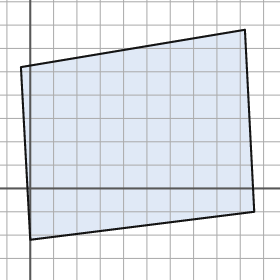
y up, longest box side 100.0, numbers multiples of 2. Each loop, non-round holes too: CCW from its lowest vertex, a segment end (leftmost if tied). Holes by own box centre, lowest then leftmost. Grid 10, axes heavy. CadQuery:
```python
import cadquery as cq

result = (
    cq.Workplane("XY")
    .moveTo(0.0, -22.0)
    .lineTo(96.0, -10.0)
    .lineTo(92.0, 68.0)
    .lineTo(-4.0, 52.0)
    .close()
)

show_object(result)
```